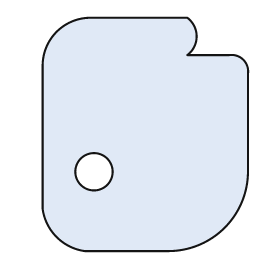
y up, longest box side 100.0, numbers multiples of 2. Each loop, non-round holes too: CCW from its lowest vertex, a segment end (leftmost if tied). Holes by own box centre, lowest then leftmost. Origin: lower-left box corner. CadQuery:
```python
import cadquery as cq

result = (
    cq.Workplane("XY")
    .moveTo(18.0, 0.0)
    .lineTo(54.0, 0.0)
    .threePointArc((78.0, 10.0), (88.0, 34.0))
    .lineTo(88.0, 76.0)
    .threePointArc((86.0, 82.0), (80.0, 84.0))
    .lineTo(62.0, 84.0)
    .threePointArc((66.0, 92.0), (62.0, 100.0))
    .lineTo(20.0, 100.0)
    .threePointArc((6.0, 94.0), (0.0, 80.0))
    .lineTo(0.0, 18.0)
    .threePointArc((6.0, 6.0), (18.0, 0.0))
    .close()
    .moveTo(22.0, 34.0)
    .circle(8.0)
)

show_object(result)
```